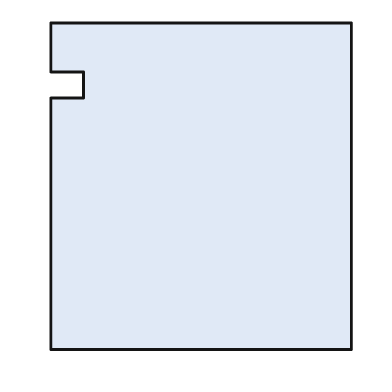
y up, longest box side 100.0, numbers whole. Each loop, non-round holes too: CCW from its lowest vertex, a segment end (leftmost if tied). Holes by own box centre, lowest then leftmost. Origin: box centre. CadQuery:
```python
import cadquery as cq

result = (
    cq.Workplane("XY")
    .moveTo(-46.0, -50.0)
    .lineTo(46.0, -50.0)
    .lineTo(46.0, 50.0)
    .lineTo(-46.0, 50.0)
    .lineTo(-46.0, 35.0)
    .lineTo(-36.0, 35.0)
    .lineTo(-36.0, 27.0)
    .lineTo(-46.0, 27.0)
    .close()
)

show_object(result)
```